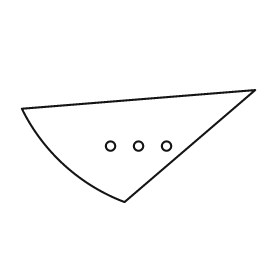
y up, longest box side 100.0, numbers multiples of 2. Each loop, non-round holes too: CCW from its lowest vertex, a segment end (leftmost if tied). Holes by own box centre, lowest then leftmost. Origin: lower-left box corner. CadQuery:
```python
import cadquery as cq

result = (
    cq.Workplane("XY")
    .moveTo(44.0, 0.0)
    .lineTo(100.0, 48.0)
    .lineTo(0.0, 40.0)
    .threePointArc((18.0, 16.0), (44.0, 0.0))
    .close()
    .moveTo(38.0, 24.0)
    .circle(2.0)
    .moveTo(50.0, 24.0)
    .circle(2.0)
    .moveTo(62.0, 24.0)
    .circle(2.0)
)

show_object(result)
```